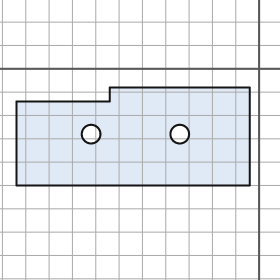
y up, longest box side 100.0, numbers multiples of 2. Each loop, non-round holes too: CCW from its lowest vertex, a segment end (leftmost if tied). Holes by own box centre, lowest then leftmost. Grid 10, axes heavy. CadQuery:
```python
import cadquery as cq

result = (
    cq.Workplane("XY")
    .moveTo(-104.0, -50.0)
    .lineTo(-4.0, -50.0)
    .lineTo(-4.0, -8.0)
    .lineTo(-64.0, -8.0)
    .lineTo(-64.0, -14.0)
    .lineTo(-104.0, -14.0)
    .close()
    .moveTo(-72.0, -28.0)
    .circle(4.0)
    .moveTo(-34.0, -28.0)
    .circle(4.0)
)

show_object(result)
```